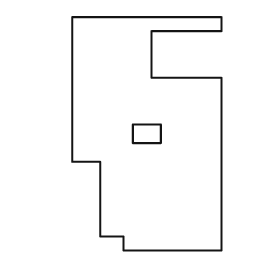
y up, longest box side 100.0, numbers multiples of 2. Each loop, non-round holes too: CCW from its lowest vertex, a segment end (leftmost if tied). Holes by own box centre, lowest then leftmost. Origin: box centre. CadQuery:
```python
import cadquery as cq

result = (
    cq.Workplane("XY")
    .moveTo(-10.0, -50.0)
    .lineTo(32.0, -50.0)
    .lineTo(32.0, 24.0)
    .lineTo(2.0, 24.0)
    .lineTo(2.0, 44.0)
    .lineTo(32.0, 44.0)
    .lineTo(32.0, 50.0)
    .lineTo(-32.0, 50.0)
    .lineTo(-32.0, -12.0)
    .lineTo(-20.0, -12.0)
    .lineTo(-20.0, -44.0)
    .lineTo(-10.0, -44.0)
    .close()
    .moveTo(-6.0, -4.0)
    .lineTo(6.0, -4.0)
    .lineTo(6.0, 4.0)
    .lineTo(-6.0, 4.0)
    .close()
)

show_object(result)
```